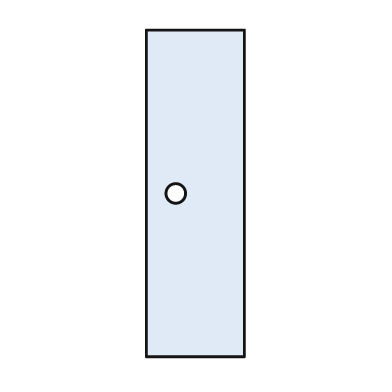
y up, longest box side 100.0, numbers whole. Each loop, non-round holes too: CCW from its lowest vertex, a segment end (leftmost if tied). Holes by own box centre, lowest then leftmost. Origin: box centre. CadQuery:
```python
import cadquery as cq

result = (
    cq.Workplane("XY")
    .moveTo(-15.0, -50.0)
    .lineTo(15.0, -50.0)
    .lineTo(15.0, 50.0)
    .lineTo(-15.0, 50.0)
    .close()
    .moveTo(-6.0, 0.0)
    .circle(3.0)
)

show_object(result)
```